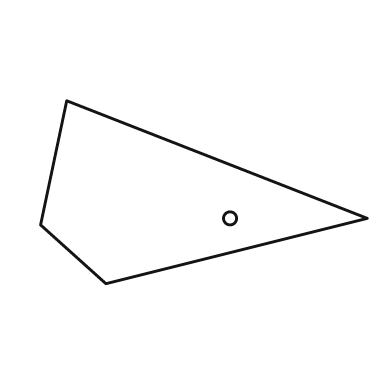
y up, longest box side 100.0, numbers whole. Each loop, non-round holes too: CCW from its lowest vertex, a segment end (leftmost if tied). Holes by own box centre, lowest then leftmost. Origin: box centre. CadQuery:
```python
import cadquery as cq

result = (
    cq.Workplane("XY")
    .moveTo(-30.0, -28.0)
    .lineTo(50.0, -8.0)
    .lineTo(-42.0, 28.0)
    .lineTo(-50.0, -10.0)
    .close()
    .moveTo(8.0, -8.0)
    .circle(2.0)
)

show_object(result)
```